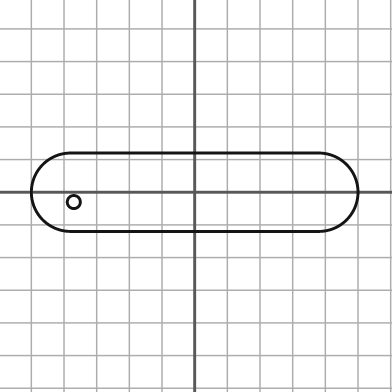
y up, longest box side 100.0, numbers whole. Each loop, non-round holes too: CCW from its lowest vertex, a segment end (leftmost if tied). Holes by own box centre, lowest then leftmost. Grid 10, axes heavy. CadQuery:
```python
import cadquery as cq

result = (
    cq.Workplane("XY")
    .moveTo(-38.0, -12.0)
    .lineTo(38.0, -12.0)
    .threePointArc((50.0, 0.0), (38.0, 12.0))
    .lineTo(-38.0, 12.0)
    .threePointArc((-50.0, 0.0), (-38.0, -12.0))
    .close()
    .moveTo(-37.0, -3.0)
    .circle(2.0)
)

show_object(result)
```